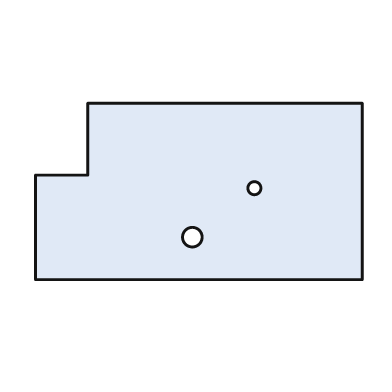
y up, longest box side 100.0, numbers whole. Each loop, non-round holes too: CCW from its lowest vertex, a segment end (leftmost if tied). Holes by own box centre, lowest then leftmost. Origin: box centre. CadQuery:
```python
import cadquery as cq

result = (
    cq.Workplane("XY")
    .moveTo(-50.0, -27.0)
    .lineTo(50.0, -27.0)
    .lineTo(50.0, 27.0)
    .lineTo(-34.0, 27.0)
    .lineTo(-34.0, 5.0)
    .lineTo(-50.0, 5.0)
    .close()
    .moveTo(-2.0, -14.0)
    .circle(3.0)
    .moveTo(17.0, 1.0)
    .circle(2.0)
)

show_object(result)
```